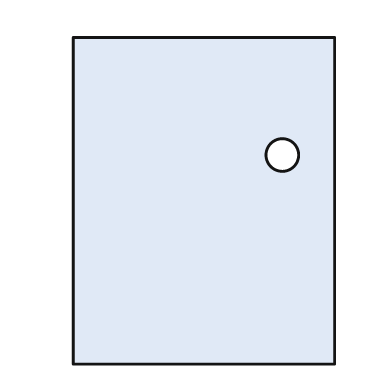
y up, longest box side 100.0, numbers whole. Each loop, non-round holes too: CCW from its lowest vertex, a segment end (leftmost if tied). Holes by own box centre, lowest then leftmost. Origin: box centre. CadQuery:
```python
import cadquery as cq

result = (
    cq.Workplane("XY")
    .moveTo(-40.0, -50.0)
    .lineTo(40.0, -50.0)
    .lineTo(40.0, 50.0)
    .lineTo(-40.0, 50.0)
    .close()
    .moveTo(24.0, 14.0)
    .circle(5.0)
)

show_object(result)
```